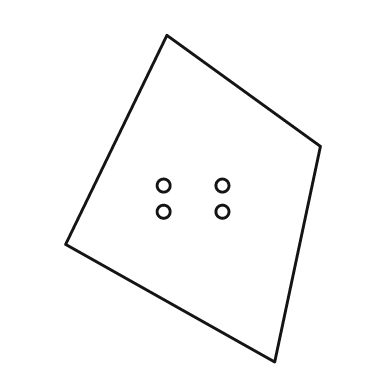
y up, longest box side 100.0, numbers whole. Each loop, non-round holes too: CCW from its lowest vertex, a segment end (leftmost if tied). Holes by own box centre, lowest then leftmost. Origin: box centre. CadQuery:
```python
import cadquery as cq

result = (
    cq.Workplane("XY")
    .moveTo(25.0, -50.0)
    .lineTo(39.0, 16.0)
    .lineTo(-8.0, 50.0)
    .lineTo(-39.0, -14.0)
    .close()
    .moveTo(-9.0, -4.0)
    .circle(2.0)
    .moveTo(9.0, -4.0)
    .circle(2.0)
    .moveTo(-9.0, 4.0)
    .circle(2.0)
    .moveTo(9.0, 4.0)
    .circle(2.0)
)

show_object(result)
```